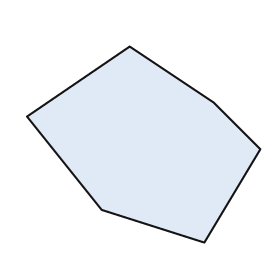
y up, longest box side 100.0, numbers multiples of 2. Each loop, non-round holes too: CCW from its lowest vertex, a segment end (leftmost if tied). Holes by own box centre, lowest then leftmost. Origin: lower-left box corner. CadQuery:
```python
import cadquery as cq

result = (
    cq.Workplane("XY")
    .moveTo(76.0, 0.0)
    .lineTo(100.0, 40.0)
    .lineTo(80.0, 60.0)
    .lineTo(44.0, 84.0)
    .lineTo(0.0, 54.0)
    .lineTo(32.0, 14.0)
    .close()
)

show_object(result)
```